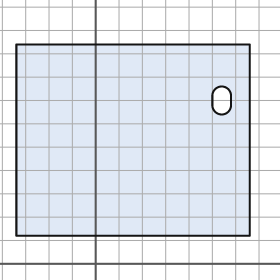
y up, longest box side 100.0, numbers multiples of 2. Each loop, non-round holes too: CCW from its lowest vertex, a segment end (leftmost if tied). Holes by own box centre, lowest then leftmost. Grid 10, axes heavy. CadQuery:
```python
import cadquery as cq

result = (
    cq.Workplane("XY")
    .moveTo(-34.0, 12.0)
    .lineTo(66.0, 12.0)
    .lineTo(66.0, 94.0)
    .lineTo(-34.0, 94.0)
    .close()
    .moveTo(50.0, 68.0)
    .threePointArc((54.0, 64.0), (58.0, 68.0))
    .lineTo(58.0, 72.0)
    .threePointArc((54.0, 76.0), (50.0, 72.0))
    .close()
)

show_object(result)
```